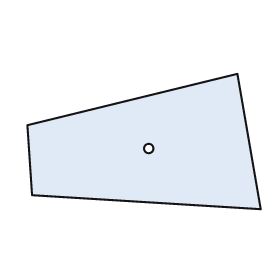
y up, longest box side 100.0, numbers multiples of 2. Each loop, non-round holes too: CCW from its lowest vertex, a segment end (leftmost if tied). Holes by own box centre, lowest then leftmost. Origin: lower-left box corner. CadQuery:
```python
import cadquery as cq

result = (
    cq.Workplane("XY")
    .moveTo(100.0, 0.0)
    .lineTo(90.0, 58.0)
    .lineTo(0.0, 36.0)
    .lineTo(2.0, 6.0)
    .close()
    .moveTo(52.0, 26.0)
    .circle(2.0)
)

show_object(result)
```